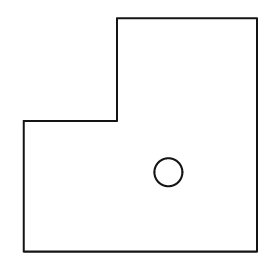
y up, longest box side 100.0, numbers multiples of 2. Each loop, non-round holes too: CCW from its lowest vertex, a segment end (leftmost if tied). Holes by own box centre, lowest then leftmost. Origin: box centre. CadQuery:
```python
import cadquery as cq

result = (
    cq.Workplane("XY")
    .moveTo(-50.0, -50.0)
    .lineTo(50.0, -50.0)
    .lineTo(50.0, 50.0)
    .lineTo(-10.0, 50.0)
    .lineTo(-10.0, 6.0)
    .lineTo(-50.0, 6.0)
    .close()
    .moveTo(12.0, -16.0)
    .circle(6.0)
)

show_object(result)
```